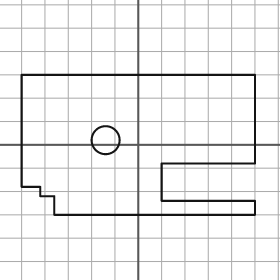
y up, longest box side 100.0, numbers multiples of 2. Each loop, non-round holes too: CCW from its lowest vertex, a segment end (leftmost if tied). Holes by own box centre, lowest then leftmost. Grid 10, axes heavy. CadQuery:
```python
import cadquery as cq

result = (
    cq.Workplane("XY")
    .moveTo(-36.0, -30.0)
    .lineTo(50.0, -30.0)
    .lineTo(50.0, -24.0)
    .lineTo(10.0, -24.0)
    .lineTo(10.0, -8.0)
    .lineTo(50.0, -8.0)
    .lineTo(50.0, 30.0)
    .lineTo(-50.0, 30.0)
    .lineTo(-50.0, -18.0)
    .lineTo(-42.0, -18.0)
    .lineTo(-42.0, -22.0)
    .lineTo(-36.0, -22.0)
    .close()
    .moveTo(-14.0, 2.0)
    .circle(6.0)
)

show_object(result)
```